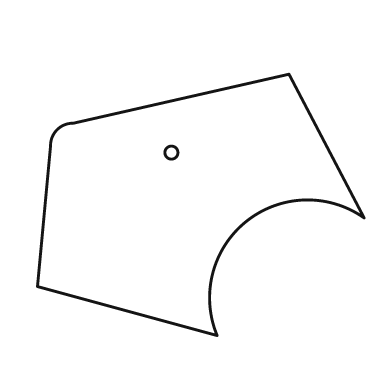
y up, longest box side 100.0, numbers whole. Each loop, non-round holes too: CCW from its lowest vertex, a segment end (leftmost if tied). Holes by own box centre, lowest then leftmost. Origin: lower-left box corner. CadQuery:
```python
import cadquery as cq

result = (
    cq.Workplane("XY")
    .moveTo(55.0, 0.0)
    .threePointArc((64.0, 35.0), (100.0, 36.0))
    .lineTo(77.0, 80.0)
    .lineTo(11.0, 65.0)
    .threePointArc((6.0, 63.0), (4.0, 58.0))
    .lineTo(0.0, 15.0)
    .close()
    .moveTo(41.0, 56.0)
    .circle(2.0)
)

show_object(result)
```